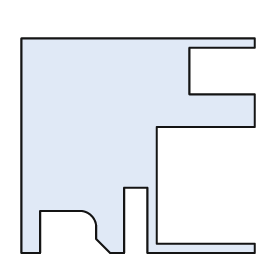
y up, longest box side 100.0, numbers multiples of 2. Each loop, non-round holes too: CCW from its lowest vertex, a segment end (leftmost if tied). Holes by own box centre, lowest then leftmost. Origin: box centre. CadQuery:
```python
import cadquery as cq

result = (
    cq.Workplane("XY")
    .moveTo(-50.0, -46.0)
    .lineTo(-42.0, -46.0)
    .lineTo(-42.0, -28.0)
    .lineTo(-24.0, -28.0)
    .threePointArc((-20.0, -30.0), (-18.0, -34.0))
    .lineTo(-18.0, -40.0)
    .lineTo(-12.0, -46.0)
    .lineTo(-6.0, -46.0)
    .lineTo(-6.0, -18.0)
    .lineTo(4.0, -18.0)
    .lineTo(4.0, -46.0)
    .lineTo(50.0, -46.0)
    .lineTo(50.0, -42.0)
    .lineTo(8.0, -42.0)
    .lineTo(8.0, 8.0)
    .lineTo(50.0, 8.0)
    .lineTo(50.0, 22.0)
    .lineTo(22.0, 22.0)
    .lineTo(22.0, 42.0)
    .lineTo(50.0, 42.0)
    .lineTo(50.0, 46.0)
    .lineTo(-50.0, 46.0)
    .close()
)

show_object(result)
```